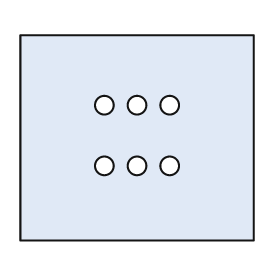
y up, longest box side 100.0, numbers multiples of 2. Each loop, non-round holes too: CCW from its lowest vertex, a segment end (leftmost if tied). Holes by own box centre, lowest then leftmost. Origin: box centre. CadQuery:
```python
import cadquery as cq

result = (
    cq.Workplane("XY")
    .moveTo(-50.0, -44.0)
    .lineTo(50.0, -44.0)
    .lineTo(50.0, 44.0)
    .lineTo(-50.0, 44.0)
    .close()
    .moveTo(-14.0, -12.0)
    .circle(4.0)
    .moveTo(0.0, -12.0)
    .circle(4.0)
    .moveTo(14.0, -12.0)
    .circle(4.0)
    .moveTo(-14.0, 14.0)
    .circle(4.0)
    .moveTo(0.0, 14.0)
    .circle(4.0)
    .moveTo(14.0, 14.0)
    .circle(4.0)
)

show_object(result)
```